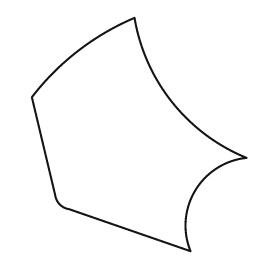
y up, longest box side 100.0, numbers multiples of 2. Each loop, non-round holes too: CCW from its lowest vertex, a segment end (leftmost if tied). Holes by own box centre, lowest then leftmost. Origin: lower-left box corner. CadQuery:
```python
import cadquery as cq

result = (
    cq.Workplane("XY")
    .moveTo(68.0, 0.0)
    .threePointArc((70.0, 26.0), (92.0, 40.0))
    .threePointArc((60.0, 64.0), (44.0, 100.0))
    .threePointArc((20.0, 86.0), (0.0, 66.0))
    .lineTo(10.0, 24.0)
    .threePointArc((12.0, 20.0), (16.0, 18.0))
    .close()
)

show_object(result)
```